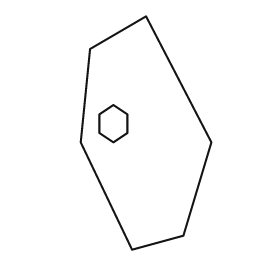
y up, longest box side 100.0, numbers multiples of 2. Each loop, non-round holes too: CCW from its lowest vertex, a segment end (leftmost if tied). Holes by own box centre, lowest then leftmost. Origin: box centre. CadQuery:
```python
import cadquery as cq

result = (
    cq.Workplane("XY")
    .moveTo(-6.0, -50.0)
    .lineTo(16.0, -44.0)
    .lineTo(28.0, -4.0)
    .lineTo(0.0, 50.0)
    .lineTo(-24.0, 36.0)
    .lineTo(-28.0, -4.0)
    .close()
    .moveTo(-14.0, -4.0)
    .lineTo(-8.0, 0.0)
    .lineTo(-8.0, 8.0)
    .lineTo(-14.0, 12.0)
    .lineTo(-20.0, 8.0)
    .lineTo(-20.0, 0.0)
    .close()
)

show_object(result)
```